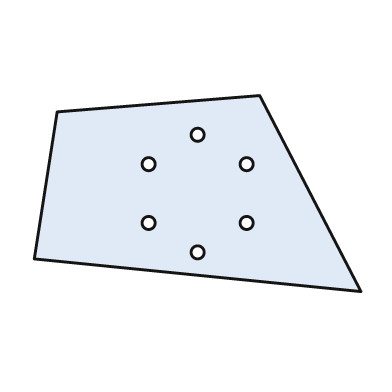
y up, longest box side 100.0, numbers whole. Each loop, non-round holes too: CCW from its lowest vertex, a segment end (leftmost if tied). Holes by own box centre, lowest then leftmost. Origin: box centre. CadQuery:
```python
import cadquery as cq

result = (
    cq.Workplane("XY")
    .moveTo(50.0, -30.0)
    .lineTo(19.0, 30.0)
    .lineTo(-43.0, 25.0)
    .lineTo(-50.0, -20.0)
    .close()
    .moveTo(0.0, -18.0)
    .circle(2.0)
    .moveTo(-15.0, -9.0)
    .circle(2.0)
    .moveTo(15.0, -9.0)
    .circle(2.0)
    .moveTo(-15.0, 9.0)
    .circle(2.0)
    .moveTo(15.0, 9.0)
    .circle(2.0)
    .moveTo(0.0, 18.0)
    .circle(2.0)
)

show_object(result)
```